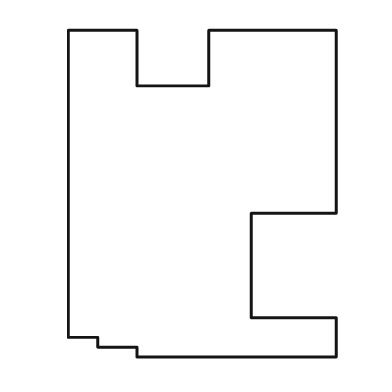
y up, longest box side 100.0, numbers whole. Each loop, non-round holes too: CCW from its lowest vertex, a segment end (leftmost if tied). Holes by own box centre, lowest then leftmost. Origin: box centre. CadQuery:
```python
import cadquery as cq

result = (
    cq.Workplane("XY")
    .moveTo(-20.0, -50.0)
    .lineTo(41.0, -50.0)
    .lineTo(41.0, -38.0)
    .lineTo(15.0, -38.0)
    .lineTo(15.0, -6.0)
    .lineTo(41.0, -6.0)
    .lineTo(41.0, 50.0)
    .lineTo(2.0, 50.0)
    .lineTo(2.0, 33.0)
    .lineTo(-20.0, 33.0)
    .lineTo(-20.0, 50.0)
    .lineTo(-41.0, 50.0)
    .lineTo(-41.0, -44.0)
    .lineTo(-32.0, -44.0)
    .lineTo(-32.0, -47.0)
    .lineTo(-20.0, -47.0)
    .close()
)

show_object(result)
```